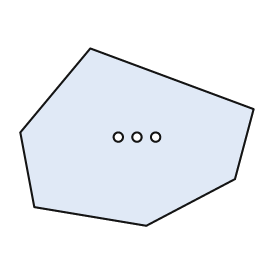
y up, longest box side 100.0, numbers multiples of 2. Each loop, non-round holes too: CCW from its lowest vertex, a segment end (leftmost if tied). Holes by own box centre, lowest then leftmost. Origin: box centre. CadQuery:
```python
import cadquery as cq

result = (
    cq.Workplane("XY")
    .moveTo(4.0, -38.0)
    .lineTo(42.0, -18.0)
    .lineTo(50.0, 12.0)
    .lineTo(-20.0, 38.0)
    .lineTo(-50.0, 2.0)
    .lineTo(-44.0, -30.0)
    .close()
    .moveTo(-8.0, 0.0)
    .circle(2.0)
    .moveTo(0.0, 0.0)
    .circle(2.0)
    .moveTo(8.0, 0.0)
    .circle(2.0)
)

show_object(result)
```